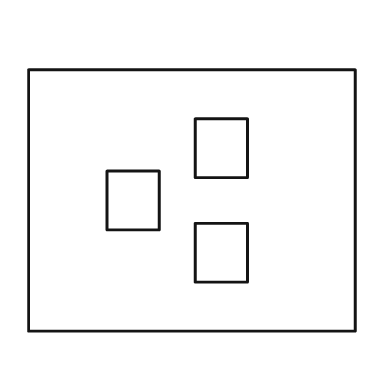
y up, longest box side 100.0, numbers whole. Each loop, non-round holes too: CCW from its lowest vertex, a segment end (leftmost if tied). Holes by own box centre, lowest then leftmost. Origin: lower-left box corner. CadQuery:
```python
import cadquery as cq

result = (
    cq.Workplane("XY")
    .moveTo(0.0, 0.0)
    .lineTo(100.0, 0.0)
    .lineTo(100.0, 80.0)
    .lineTo(0.0, 80.0)
    .close()
    .moveTo(51.0, 15.0)
    .lineTo(67.0, 15.0)
    .lineTo(67.0, 33.0)
    .lineTo(51.0, 33.0)
    .close()
    .moveTo(24.0, 31.0)
    .lineTo(40.0, 31.0)
    .lineTo(40.0, 49.0)
    .lineTo(24.0, 49.0)
    .close()
    .moveTo(51.0, 47.0)
    .lineTo(67.0, 47.0)
    .lineTo(67.0, 65.0)
    .lineTo(51.0, 65.0)
    .close()
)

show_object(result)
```